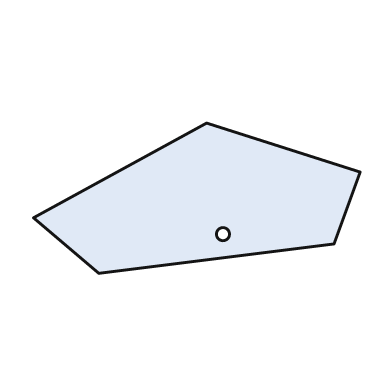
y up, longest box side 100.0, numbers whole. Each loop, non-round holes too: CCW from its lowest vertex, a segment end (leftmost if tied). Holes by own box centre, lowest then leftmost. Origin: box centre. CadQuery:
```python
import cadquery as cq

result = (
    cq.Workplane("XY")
    .moveTo(-30.0, -23.0)
    .lineTo(42.0, -14.0)
    .lineTo(50.0, 8.0)
    .lineTo(3.0, 23.0)
    .lineTo(-50.0, -6.0)
    .close()
    .moveTo(8.0, -11.0)
    .circle(2.0)
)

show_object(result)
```